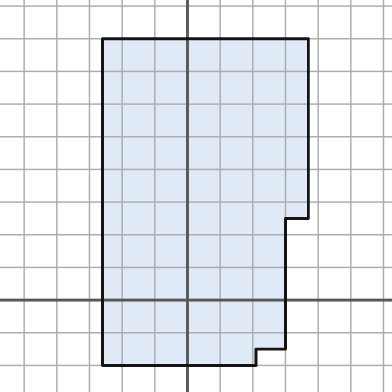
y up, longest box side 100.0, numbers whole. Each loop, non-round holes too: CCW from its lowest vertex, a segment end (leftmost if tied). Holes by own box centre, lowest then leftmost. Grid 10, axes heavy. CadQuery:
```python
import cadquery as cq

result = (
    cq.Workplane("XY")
    .moveTo(-26.0, -20.0)
    .lineTo(21.0, -20.0)
    .lineTo(21.0, -15.0)
    .lineTo(30.0, -15.0)
    .lineTo(30.0, 25.0)
    .lineTo(37.0, 25.0)
    .lineTo(37.0, 80.0)
    .lineTo(-26.0, 80.0)
    .close()
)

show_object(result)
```